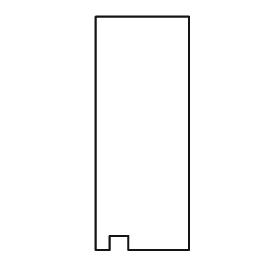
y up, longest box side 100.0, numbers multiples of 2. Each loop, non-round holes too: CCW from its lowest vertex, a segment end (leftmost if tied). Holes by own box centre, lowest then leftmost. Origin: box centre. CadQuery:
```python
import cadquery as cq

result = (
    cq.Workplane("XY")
    .moveTo(-20.0, -50.0)
    .lineTo(-14.0, -50.0)
    .lineTo(-14.0, -44.0)
    .lineTo(-6.0, -44.0)
    .lineTo(-6.0, -50.0)
    .lineTo(20.0, -50.0)
    .lineTo(20.0, 50.0)
    .lineTo(-20.0, 50.0)
    .close()
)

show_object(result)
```